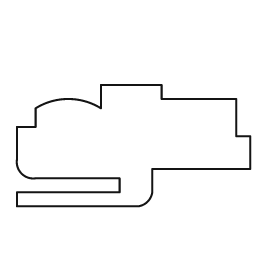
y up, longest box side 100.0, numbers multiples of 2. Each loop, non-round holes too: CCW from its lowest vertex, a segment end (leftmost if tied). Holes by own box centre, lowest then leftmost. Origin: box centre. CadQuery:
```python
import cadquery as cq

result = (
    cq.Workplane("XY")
    .moveTo(-50.0, -26.0)
    .lineTo(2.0, -26.0)
    .threePointArc((6.0, -24.0), (8.0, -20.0))
    .lineTo(8.0, -10.0)
    .lineTo(50.0, -10.0)
    .lineTo(50.0, 4.0)
    .lineTo(44.0, 4.0)
    .lineTo(44.0, 20.0)
    .lineTo(12.0, 20.0)
    .lineTo(12.0, 26.0)
    .lineTo(-14.0, 26.0)
    .lineTo(-14.0, 16.0)
    .threePointArc((-28.0, 20.0), (-42.0, 16.0))
    .lineTo(-42.0, 8.0)
    .lineTo(-50.0, 8.0)
    .lineTo(-50.0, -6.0)
    .threePointArc((-48.0, -12.0), (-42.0, -14.0))
    .lineTo(-6.0, -14.0)
    .lineTo(-6.0, -20.0)
    .lineTo(-50.0, -20.0)
    .close()
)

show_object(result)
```